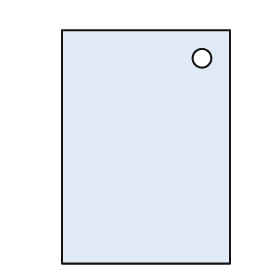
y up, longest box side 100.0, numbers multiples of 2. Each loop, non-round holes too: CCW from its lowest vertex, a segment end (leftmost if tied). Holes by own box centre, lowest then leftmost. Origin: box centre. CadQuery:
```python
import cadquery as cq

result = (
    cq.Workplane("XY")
    .moveTo(-36.0, -50.0)
    .lineTo(36.0, -50.0)
    .lineTo(36.0, 50.0)
    .lineTo(-36.0, 50.0)
    .close()
    .moveTo(24.0, 38.0)
    .circle(4.0)
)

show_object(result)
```